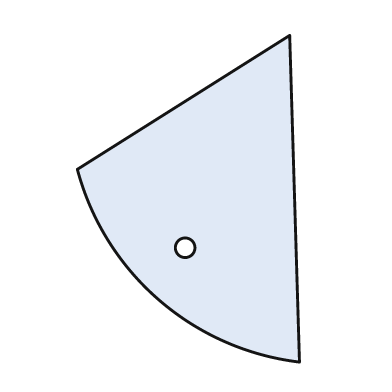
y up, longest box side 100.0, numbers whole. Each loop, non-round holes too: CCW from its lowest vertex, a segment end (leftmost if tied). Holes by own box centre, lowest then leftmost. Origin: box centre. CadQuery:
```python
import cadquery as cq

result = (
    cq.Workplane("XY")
    .moveTo(34.0, -50.0)
    .lineTo(31.0, 50.0)
    .lineTo(-34.0, 9.0)
    .threePointArc((-9.0, -31.0), (34.0, -50.0))
    .close()
    .moveTo(-1.0, -15.0)
    .circle(3.0)
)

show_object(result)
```